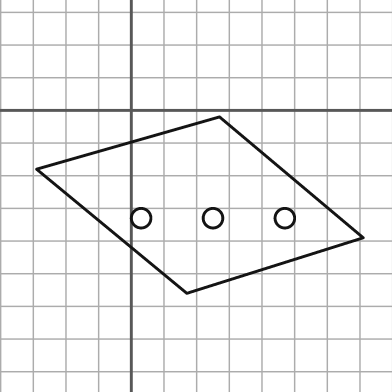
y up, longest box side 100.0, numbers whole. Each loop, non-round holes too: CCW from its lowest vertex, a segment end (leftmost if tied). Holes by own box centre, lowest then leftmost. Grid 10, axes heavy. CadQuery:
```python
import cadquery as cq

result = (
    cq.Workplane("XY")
    .moveTo(17.0, -56.0)
    .lineTo(71.0, -39.0)
    .lineTo(27.0, -2.0)
    .lineTo(-29.0, -18.0)
    .close()
    .moveTo(3.0, -33.0)
    .circle(3.0)
    .moveTo(25.0, -33.0)
    .circle(3.0)
    .moveTo(47.0, -33.0)
    .circle(3.0)
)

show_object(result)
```